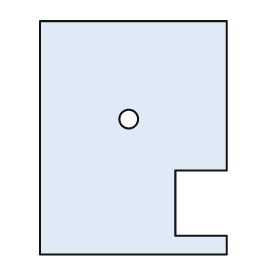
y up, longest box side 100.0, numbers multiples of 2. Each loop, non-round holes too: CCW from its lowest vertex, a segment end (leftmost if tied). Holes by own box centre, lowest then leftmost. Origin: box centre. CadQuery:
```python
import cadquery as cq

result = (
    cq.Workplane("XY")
    .moveTo(-40.0, -50.0)
    .lineTo(40.0, -50.0)
    .lineTo(40.0, -42.0)
    .lineTo(18.0, -42.0)
    .lineTo(18.0, -14.0)
    .lineTo(40.0, -14.0)
    .lineTo(40.0, 50.0)
    .lineTo(-40.0, 50.0)
    .close()
    .moveTo(-2.0, 8.0)
    .circle(4.0)
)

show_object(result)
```